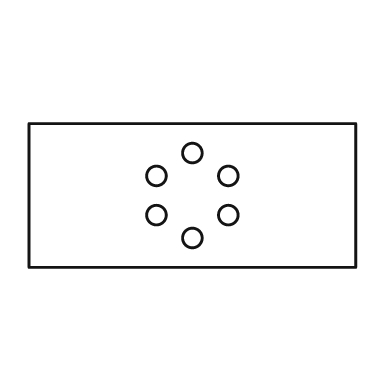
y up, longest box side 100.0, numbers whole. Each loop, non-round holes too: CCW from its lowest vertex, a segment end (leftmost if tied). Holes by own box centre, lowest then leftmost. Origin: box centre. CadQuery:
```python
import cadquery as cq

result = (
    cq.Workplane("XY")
    .moveTo(-50.0, -22.0)
    .lineTo(50.0, -22.0)
    .lineTo(50.0, 22.0)
    .lineTo(-50.0, 22.0)
    .close()
    .moveTo(0.0, -13.0)
    .circle(3.0)
    .moveTo(-11.0, -6.0)
    .circle(3.0)
    .moveTo(11.0, -6.0)
    .circle(3.0)
    .moveTo(-11.0, 6.0)
    .circle(3.0)
    .moveTo(11.0, 6.0)
    .circle(3.0)
    .moveTo(0.0, 13.0)
    .circle(3.0)
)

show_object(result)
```